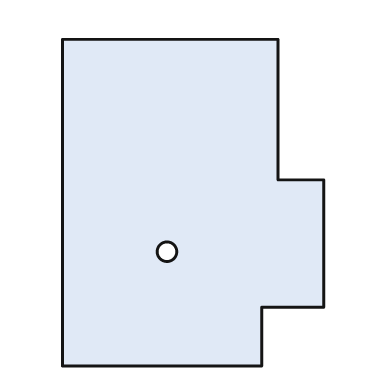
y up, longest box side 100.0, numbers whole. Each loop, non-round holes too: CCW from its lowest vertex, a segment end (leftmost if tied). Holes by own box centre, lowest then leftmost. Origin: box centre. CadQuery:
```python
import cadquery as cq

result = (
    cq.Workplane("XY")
    .moveTo(-40.0, -50.0)
    .lineTo(21.0, -50.0)
    .lineTo(21.0, -32.0)
    .lineTo(40.0, -32.0)
    .lineTo(40.0, 7.0)
    .lineTo(26.0, 7.0)
    .lineTo(26.0, 50.0)
    .lineTo(-40.0, 50.0)
    .close()
    .moveTo(-8.0, -15.0)
    .circle(3.0)
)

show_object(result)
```